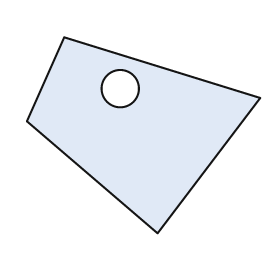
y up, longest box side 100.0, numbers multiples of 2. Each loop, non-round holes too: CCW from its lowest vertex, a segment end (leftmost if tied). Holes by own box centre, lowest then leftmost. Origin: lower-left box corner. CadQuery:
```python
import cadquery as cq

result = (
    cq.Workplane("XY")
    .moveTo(56.0, 0.0)
    .lineTo(100.0, 58.0)
    .lineTo(16.0, 84.0)
    .lineTo(0.0, 48.0)
    .close()
    .moveTo(40.0, 62.0)
    .circle(8.0)
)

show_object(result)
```